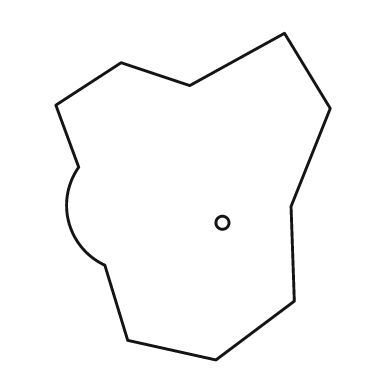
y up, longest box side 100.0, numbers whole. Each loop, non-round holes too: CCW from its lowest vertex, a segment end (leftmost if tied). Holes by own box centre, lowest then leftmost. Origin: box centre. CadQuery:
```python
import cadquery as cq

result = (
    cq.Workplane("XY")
    .moveTo(7.0, -50.0)
    .lineTo(31.0, -32.0)
    .lineTo(30.0, -3.0)
    .lineTo(42.0, 27.0)
    .lineTo(28.0, 50.0)
    .lineTo(-1.0, 34.0)
    .lineTo(-22.0, 41.0)
    .lineTo(-42.0, 28.0)
    .lineTo(-35.0, 9.0)
    .threePointArc((-38.0, -8.0), (-27.0, -21.0))
    .lineTo(-20.0, -44.0)
    .close()
    .moveTo(9.0, -8.0)
    .circle(2.0)
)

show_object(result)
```